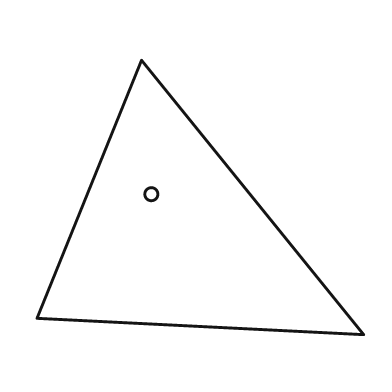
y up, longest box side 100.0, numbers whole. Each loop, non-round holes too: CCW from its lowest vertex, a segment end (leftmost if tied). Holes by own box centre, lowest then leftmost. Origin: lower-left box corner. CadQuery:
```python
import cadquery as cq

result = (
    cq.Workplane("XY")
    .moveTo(100.0, 0.0)
    .lineTo(32.0, 84.0)
    .lineTo(0.0, 5.0)
    .close()
    .moveTo(35.0, 43.0)
    .circle(2.0)
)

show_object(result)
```